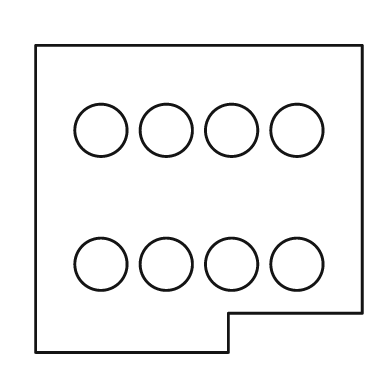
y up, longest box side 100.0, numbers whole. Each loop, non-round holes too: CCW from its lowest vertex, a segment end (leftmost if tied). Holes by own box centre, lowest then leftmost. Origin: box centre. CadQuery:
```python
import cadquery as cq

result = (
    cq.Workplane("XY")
    .moveTo(-50.0, -47.0)
    .lineTo(9.0, -47.0)
    .lineTo(9.0, -35.0)
    .lineTo(50.0, -35.0)
    .lineTo(50.0, 47.0)
    .lineTo(-50.0, 47.0)
    .close()
    .moveTo(-30.0, -20.0)
    .circle(8.0)
    .moveTo(-10.0, -20.0)
    .circle(8.0)
    .moveTo(10.0, -20.0)
    .circle(8.0)
    .moveTo(30.0, -20.0)
    .circle(8.0)
    .moveTo(-30.0, 21.0)
    .circle(8.0)
    .moveTo(-10.0, 21.0)
    .circle(8.0)
    .moveTo(10.0, 21.0)
    .circle(8.0)
    .moveTo(30.0, 21.0)
    .circle(8.0)
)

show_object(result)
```